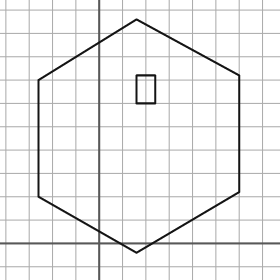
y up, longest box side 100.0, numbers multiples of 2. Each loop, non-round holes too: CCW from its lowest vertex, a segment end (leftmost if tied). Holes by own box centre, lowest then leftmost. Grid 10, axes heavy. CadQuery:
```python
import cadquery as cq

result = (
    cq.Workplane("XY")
    .moveTo(16.0, -4.0)
    .lineTo(60.0, 22.0)
    .lineTo(60.0, 72.0)
    .lineTo(16.0, 96.0)
    .lineTo(-26.0, 70.0)
    .lineTo(-26.0, 20.0)
    .close()
    .moveTo(16.0, 60.0)
    .lineTo(24.0, 60.0)
    .lineTo(24.0, 72.0)
    .lineTo(16.0, 72.0)
    .close()
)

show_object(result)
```